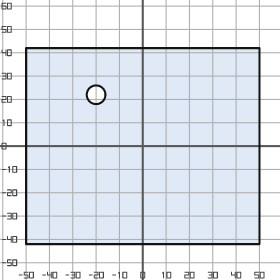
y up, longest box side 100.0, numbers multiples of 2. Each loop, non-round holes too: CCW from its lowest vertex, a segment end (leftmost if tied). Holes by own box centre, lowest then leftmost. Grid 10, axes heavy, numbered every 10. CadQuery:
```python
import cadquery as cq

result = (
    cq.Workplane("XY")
    .moveTo(-50.0, -42.0)
    .lineTo(50.0, -42.0)
    .lineTo(50.0, 42.0)
    .lineTo(-50.0, 42.0)
    .close()
    .moveTo(-20.0, 22.0)
    .circle(4.0)
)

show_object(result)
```